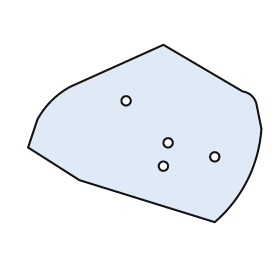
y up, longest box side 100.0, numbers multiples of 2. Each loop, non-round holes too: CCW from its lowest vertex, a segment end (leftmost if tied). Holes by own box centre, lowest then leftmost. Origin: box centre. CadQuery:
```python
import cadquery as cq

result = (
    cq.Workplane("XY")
    .moveTo(30.0, -38.0)
    .threePointArc((44.0, -20.0), (50.0, 2.0))
    .lineTo(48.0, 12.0)
    .threePointArc((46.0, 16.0), (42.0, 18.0))
    .lineTo(8.0, 38.0)
    .lineTo(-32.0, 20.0)
    .threePointArc((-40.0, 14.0), (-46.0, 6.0))
    .lineTo(-50.0, -6.0)
    .lineTo(-28.0, -20.0)
    .close()
    .moveTo(8.0, -14.0)
    .circle(2.0)
    .moveTo(30.0, -10.0)
    .circle(2.0)
    .moveTo(10.0, -4.0)
    .circle(2.0)
    .moveTo(-8.0, 14.0)
    .circle(2.0)
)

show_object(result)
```